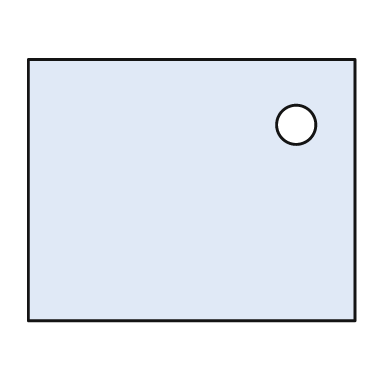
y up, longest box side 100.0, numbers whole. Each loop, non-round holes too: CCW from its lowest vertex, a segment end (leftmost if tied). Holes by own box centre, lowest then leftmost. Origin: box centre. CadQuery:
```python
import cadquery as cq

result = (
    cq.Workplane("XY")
    .moveTo(-50.0, -40.0)
    .lineTo(50.0, -40.0)
    .lineTo(50.0, 40.0)
    .lineTo(-50.0, 40.0)
    .close()
    .moveTo(32.0, 20.0)
    .circle(6.0)
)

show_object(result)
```